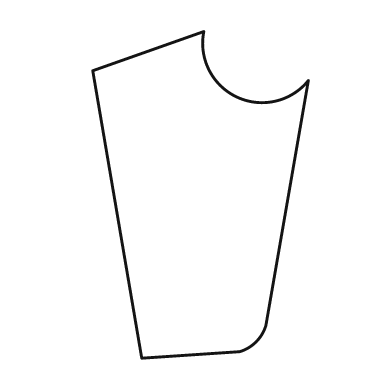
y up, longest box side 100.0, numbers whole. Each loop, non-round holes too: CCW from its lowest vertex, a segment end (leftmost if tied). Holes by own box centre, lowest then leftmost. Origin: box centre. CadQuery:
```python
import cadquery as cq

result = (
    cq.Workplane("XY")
    .moveTo(-18.0, -50.0)
    .lineTo(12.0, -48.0)
    .threePointArc((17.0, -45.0), (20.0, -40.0))
    .lineTo(33.0, 35.0)
    .threePointArc((11.0, 30.0), (1.0, 50.0))
    .lineTo(-33.0, 38.0)
    .close()
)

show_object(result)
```